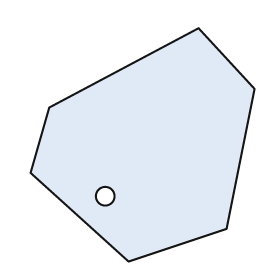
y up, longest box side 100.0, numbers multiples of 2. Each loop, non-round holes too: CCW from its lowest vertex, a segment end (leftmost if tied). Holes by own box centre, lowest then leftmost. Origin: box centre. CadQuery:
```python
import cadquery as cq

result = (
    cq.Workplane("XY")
    .moveTo(-6.0, -50.0)
    .lineTo(36.0, -36.0)
    .lineTo(48.0, 24.0)
    .lineTo(24.0, 50.0)
    .lineTo(-40.0, 16.0)
    .lineTo(-48.0, -12.0)
    .close()
    .moveTo(-16.0, -22.0)
    .circle(4.0)
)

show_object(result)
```